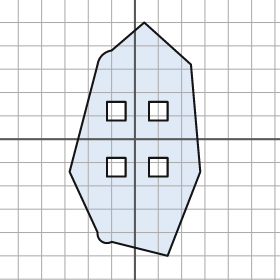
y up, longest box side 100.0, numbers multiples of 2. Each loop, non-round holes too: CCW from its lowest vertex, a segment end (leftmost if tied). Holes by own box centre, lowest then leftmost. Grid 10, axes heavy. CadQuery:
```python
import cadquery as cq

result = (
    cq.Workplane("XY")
    .moveTo(14.0, -50.0)
    .lineTo(28.0, -14.0)
    .lineTo(24.0, 32.0)
    .lineTo(4.0, 50.0)
    .lineTo(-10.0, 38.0)
    .threePointArc((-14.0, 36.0), (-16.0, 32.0))
    .lineTo(-28.0, -14.0)
    .lineTo(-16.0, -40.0)
    .threePointArc((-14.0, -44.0), (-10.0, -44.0))
    .close()
    .moveTo(-12.0, -16.0)
    .lineTo(-4.0, -16.0)
    .lineTo(-4.0, -8.0)
    .lineTo(-12.0, -8.0)
    .close()
    .moveTo(6.0, -16.0)
    .lineTo(14.0, -16.0)
    .lineTo(14.0, -8.0)
    .lineTo(6.0, -8.0)
    .close()
    .moveTo(-12.0, 8.0)
    .lineTo(-4.0, 8.0)
    .lineTo(-4.0, 16.0)
    .lineTo(-12.0, 16.0)
    .close()
    .moveTo(6.0, 8.0)
    .lineTo(14.0, 8.0)
    .lineTo(14.0, 16.0)
    .lineTo(6.0, 16.0)
    .close()
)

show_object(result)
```